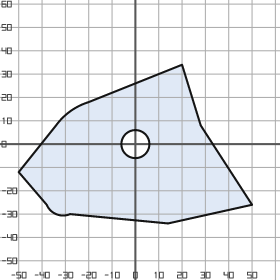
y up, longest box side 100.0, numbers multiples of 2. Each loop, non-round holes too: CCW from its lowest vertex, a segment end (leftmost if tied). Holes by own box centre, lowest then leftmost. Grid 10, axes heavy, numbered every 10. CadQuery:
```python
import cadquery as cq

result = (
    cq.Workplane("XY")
    .moveTo(14.0, -34.0)
    .lineTo(50.0, -26.0)
    .lineTo(28.0, 8.0)
    .lineTo(20.0, 34.0)
    .lineTo(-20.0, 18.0)
    .threePointArc((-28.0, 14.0), (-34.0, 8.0))
    .lineTo(-50.0, -12.0)
    .lineTo(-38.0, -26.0)
    .threePointArc((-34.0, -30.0), (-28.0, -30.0))
    .close()
    .moveTo(0.0, 0.0)
    .circle(6.0)
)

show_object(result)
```